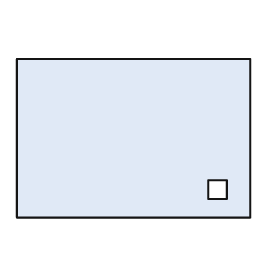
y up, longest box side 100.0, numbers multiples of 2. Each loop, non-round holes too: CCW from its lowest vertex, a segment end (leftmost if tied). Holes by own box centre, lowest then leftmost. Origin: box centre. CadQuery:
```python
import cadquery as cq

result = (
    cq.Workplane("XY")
    .moveTo(-50.0, -34.0)
    .lineTo(50.0, -34.0)
    .lineTo(50.0, 34.0)
    .lineTo(-50.0, 34.0)
    .close()
    .moveTo(32.0, -26.0)
    .lineTo(40.0, -26.0)
    .lineTo(40.0, -18.0)
    .lineTo(32.0, -18.0)
    .close()
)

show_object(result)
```